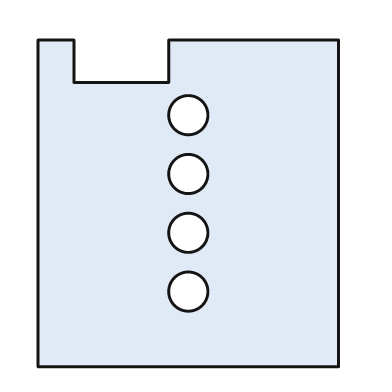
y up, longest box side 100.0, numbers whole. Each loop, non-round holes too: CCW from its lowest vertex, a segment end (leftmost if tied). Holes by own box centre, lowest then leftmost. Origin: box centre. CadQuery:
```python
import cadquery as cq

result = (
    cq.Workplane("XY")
    .moveTo(-46.0, -50.0)
    .lineTo(46.0, -50.0)
    .lineTo(46.0, 50.0)
    .lineTo(-6.0, 50.0)
    .lineTo(-6.0, 37.0)
    .lineTo(-35.0, 37.0)
    .lineTo(-35.0, 50.0)
    .lineTo(-46.0, 50.0)
    .close()
    .moveTo(0.0, -27.0)
    .circle(6.0)
    .moveTo(0.0, -9.0)
    .circle(6.0)
    .moveTo(0.0, 9.0)
    .circle(6.0)
    .moveTo(0.0, 27.0)
    .circle(6.0)
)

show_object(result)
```